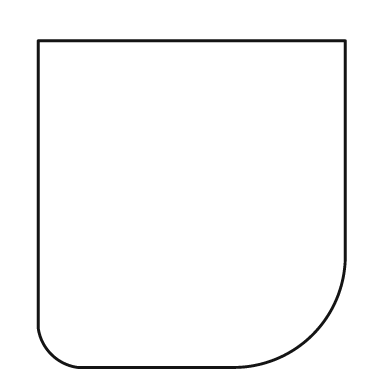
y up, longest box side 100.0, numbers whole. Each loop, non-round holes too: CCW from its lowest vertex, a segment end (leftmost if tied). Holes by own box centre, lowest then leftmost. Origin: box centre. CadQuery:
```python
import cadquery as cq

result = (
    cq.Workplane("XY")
    .moveTo(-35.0, -50.0)
    .lineTo(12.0, -50.0)
    .threePointArc((37.0, -40.0), (47.0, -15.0))
    .lineTo(47.0, 50.0)
    .lineTo(-47.0, 50.0)
    .lineTo(-47.0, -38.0)
    .threePointArc((-43.0, -46.0), (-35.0, -50.0))
    .close()
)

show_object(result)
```